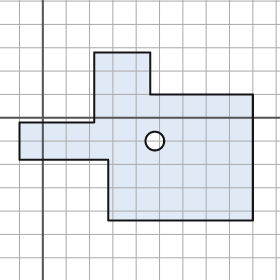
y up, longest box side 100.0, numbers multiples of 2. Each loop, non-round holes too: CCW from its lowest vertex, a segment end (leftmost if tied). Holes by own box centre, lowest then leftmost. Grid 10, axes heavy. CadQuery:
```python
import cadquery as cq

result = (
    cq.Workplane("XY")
    .moveTo(28.0, -44.0)
    .lineTo(90.0, -44.0)
    .lineTo(90.0, 10.0)
    .lineTo(46.0, 10.0)
    .lineTo(46.0, 28.0)
    .lineTo(22.0, 28.0)
    .lineTo(22.0, -2.0)
    .lineTo(-10.0, -2.0)
    .lineTo(-10.0, -18.0)
    .lineTo(28.0, -18.0)
    .close()
    .moveTo(48.0, -10.0)
    .circle(4.0)
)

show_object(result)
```